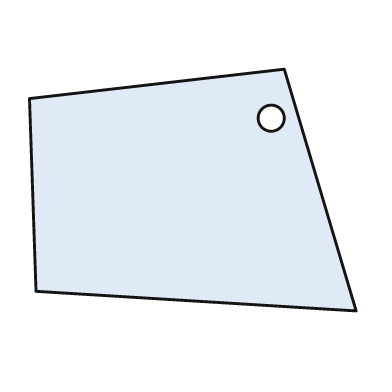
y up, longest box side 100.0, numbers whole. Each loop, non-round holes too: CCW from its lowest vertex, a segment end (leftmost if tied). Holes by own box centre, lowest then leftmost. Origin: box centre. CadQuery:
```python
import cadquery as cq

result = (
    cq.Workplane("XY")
    .moveTo(50.0, -37.0)
    .lineTo(28.0, 37.0)
    .lineTo(-50.0, 28.0)
    .lineTo(-48.0, -31.0)
    .close()
    .moveTo(24.0, 22.0)
    .circle(4.0)
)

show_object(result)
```